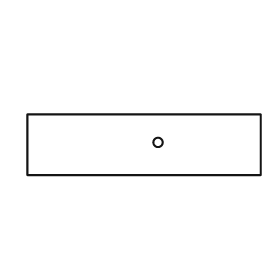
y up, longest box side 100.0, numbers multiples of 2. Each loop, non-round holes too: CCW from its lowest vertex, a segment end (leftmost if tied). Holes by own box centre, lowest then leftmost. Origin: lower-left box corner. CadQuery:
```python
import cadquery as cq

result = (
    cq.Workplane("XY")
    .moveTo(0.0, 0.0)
    .lineTo(100.0, 0.0)
    .lineTo(100.0, 26.0)
    .lineTo(0.0, 26.0)
    .close()
    .moveTo(56.0, 14.0)
    .circle(2.0)
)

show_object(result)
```